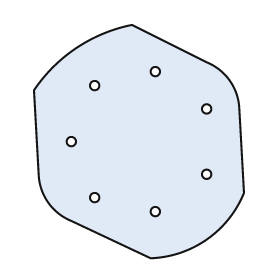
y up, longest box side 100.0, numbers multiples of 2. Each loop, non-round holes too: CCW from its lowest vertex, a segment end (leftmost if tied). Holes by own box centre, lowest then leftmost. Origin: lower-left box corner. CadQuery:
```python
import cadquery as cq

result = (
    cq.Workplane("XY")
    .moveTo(50.0, 0.0)
    .threePointArc((74.0, 8.0), (90.0, 28.0))
    .lineTo(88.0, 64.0)
    .threePointArc((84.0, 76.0), (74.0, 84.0))
    .lineTo(42.0, 100.0)
    .threePointArc((18.0, 90.0), (0.0, 72.0))
    .lineTo(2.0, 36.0)
    .threePointArc((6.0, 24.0), (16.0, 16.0))
    .close()
    .moveTo(52.0, 20.0)
    .circle(2.0)
    .moveTo(26.0, 26.0)
    .circle(2.0)
    .moveTo(74.0, 36.0)
    .circle(2.0)
    .moveTo(16.0, 50.0)
    .circle(2.0)
    .moveTo(74.0, 64.0)
    .circle(2.0)
    .moveTo(26.0, 74.0)
    .circle(2.0)
    .moveTo(52.0, 80.0)
    .circle(2.0)
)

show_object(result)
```